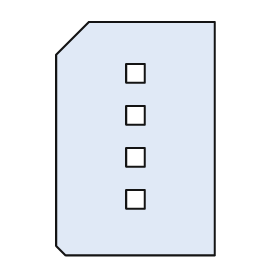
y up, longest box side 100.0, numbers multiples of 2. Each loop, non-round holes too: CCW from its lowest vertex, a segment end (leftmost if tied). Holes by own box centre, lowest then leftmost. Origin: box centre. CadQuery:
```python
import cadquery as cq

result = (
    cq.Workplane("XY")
    .moveTo(-30.0, -50.0)
    .lineTo(34.0, -50.0)
    .lineTo(34.0, 50.0)
    .lineTo(-20.0, 50.0)
    .lineTo(-34.0, 36.0)
    .lineTo(-34.0, -46.0)
    .close()
    .moveTo(-4.0, -30.0)
    .lineTo(4.0, -30.0)
    .lineTo(4.0, -22.0)
    .lineTo(-4.0, -22.0)
    .close()
    .moveTo(-4.0, -12.0)
    .lineTo(4.0, -12.0)
    .lineTo(4.0, -4.0)
    .lineTo(-4.0, -4.0)
    .close()
    .moveTo(-4.0, 6.0)
    .lineTo(4.0, 6.0)
    .lineTo(4.0, 14.0)
    .lineTo(-4.0, 14.0)
    .close()
    .moveTo(-4.0, 24.0)
    .lineTo(4.0, 24.0)
    .lineTo(4.0, 32.0)
    .lineTo(-4.0, 32.0)
    .close()
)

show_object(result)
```